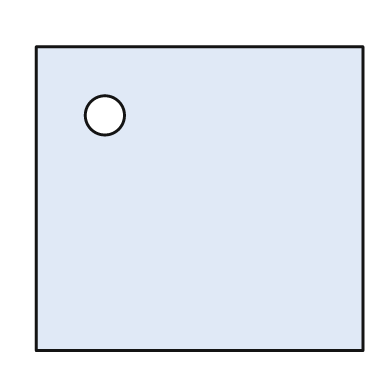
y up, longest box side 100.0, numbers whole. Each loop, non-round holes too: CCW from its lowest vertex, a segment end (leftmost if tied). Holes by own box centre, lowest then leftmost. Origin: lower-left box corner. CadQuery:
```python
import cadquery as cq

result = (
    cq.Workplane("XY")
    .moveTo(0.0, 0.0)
    .lineTo(100.0, 0.0)
    .lineTo(100.0, 93.0)
    .lineTo(0.0, 93.0)
    .close()
    .moveTo(21.0, 72.0)
    .circle(6.0)
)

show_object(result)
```